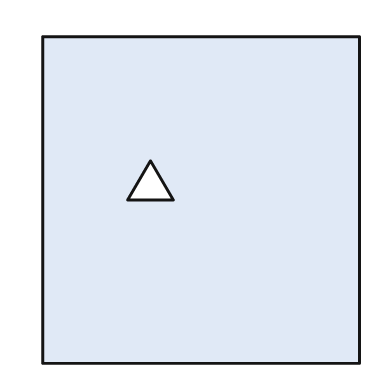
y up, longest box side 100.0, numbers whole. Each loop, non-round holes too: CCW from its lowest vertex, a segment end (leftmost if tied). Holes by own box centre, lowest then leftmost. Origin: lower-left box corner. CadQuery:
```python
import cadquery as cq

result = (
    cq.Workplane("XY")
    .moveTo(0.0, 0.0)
    .lineTo(97.0, 0.0)
    .lineTo(97.0, 100.0)
    .lineTo(0.0, 100.0)
    .close()
    .moveTo(26.0, 50.0)
    .lineTo(40.0, 50.0)
    .lineTo(33.0, 62.0)
    .close()
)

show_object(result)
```